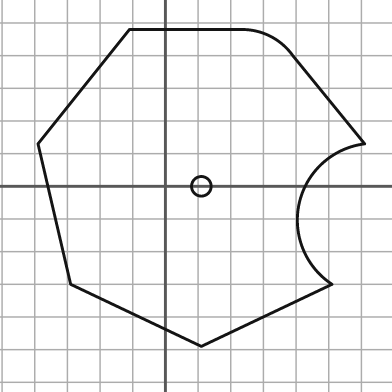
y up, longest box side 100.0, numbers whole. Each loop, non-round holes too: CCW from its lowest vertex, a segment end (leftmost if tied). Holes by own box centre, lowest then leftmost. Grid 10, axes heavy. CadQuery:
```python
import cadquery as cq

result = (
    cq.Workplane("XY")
    .moveTo(11.0, -49.0)
    .lineTo(51.0, -30.0)
    .threePointArc((41.0, -5.0), (61.0, 13.0))
    .lineTo(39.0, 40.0)
    .threePointArc((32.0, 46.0), (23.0, 48.0))
    .lineTo(-11.0, 48.0)
    .lineTo(-39.0, 13.0)
    .lineTo(-29.0, -30.0)
    .close()
    .moveTo(11.0, 0.0)
    .circle(3.0)
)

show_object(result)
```